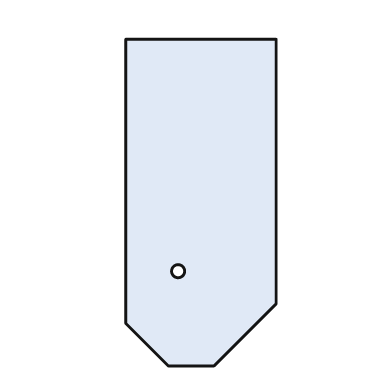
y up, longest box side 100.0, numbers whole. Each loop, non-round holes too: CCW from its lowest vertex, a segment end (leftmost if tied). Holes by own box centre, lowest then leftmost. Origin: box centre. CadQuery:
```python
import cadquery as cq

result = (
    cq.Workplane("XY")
    .moveTo(-10.0, -50.0)
    .lineTo(4.0, -50.0)
    .lineTo(23.0, -31.0)
    .lineTo(23.0, 50.0)
    .lineTo(-23.0, 50.0)
    .lineTo(-23.0, -37.0)
    .close()
    .moveTo(-7.0, -21.0)
    .circle(2.0)
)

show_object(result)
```